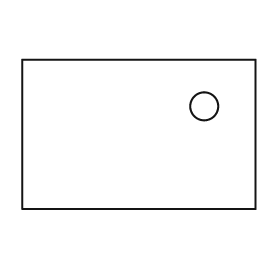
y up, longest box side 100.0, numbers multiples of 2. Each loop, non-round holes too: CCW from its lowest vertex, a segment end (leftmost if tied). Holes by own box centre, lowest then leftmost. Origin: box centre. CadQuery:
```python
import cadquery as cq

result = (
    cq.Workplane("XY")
    .moveTo(-50.0, -32.0)
    .lineTo(50.0, -32.0)
    .lineTo(50.0, 32.0)
    .lineTo(-50.0, 32.0)
    .close()
    .moveTo(28.0, 12.0)
    .circle(6.0)
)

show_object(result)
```